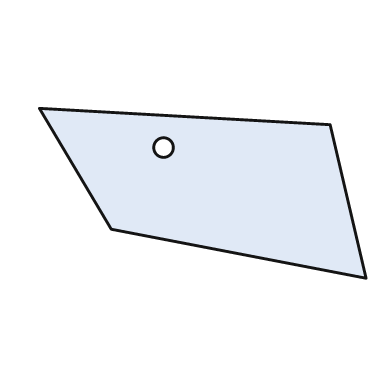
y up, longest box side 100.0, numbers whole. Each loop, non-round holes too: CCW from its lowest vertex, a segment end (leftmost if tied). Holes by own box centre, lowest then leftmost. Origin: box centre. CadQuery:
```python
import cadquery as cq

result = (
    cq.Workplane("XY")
    .moveTo(50.0, -26.0)
    .lineTo(39.0, 21.0)
    .lineTo(-50.0, 26.0)
    .lineTo(-28.0, -11.0)
    .close()
    .moveTo(-12.0, 14.0)
    .circle(3.0)
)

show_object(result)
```